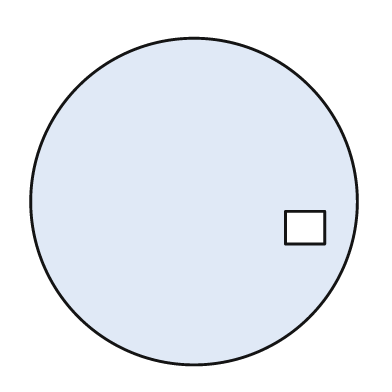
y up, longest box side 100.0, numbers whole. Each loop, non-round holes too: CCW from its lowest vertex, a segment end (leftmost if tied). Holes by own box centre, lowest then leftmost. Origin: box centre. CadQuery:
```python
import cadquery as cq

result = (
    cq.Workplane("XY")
    .moveTo(0.0, 0.0)
    .circle(50.0)
    .moveTo(28.0, -13.0)
    .lineTo(40.0, -13.0)
    .lineTo(40.0, -3.0)
    .lineTo(28.0, -3.0)
    .close()
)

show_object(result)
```